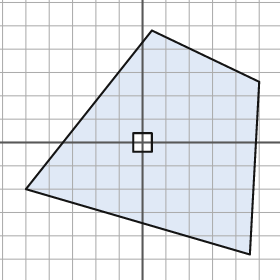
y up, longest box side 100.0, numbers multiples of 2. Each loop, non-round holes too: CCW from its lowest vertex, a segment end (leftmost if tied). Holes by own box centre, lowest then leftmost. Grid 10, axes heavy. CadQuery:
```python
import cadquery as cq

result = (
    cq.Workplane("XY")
    .moveTo(46.0, -48.0)
    .lineTo(50.0, 26.0)
    .lineTo(4.0, 48.0)
    .lineTo(-50.0, -20.0)
    .close()
    .moveTo(-4.0, -4.0)
    .lineTo(4.0, -4.0)
    .lineTo(4.0, 4.0)
    .lineTo(-4.0, 4.0)
    .close()
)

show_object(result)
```